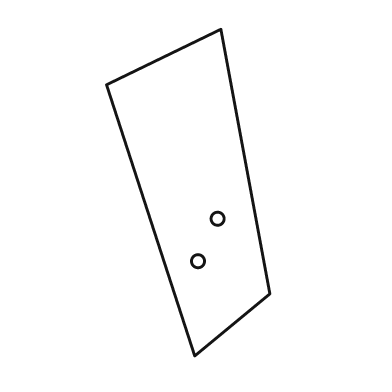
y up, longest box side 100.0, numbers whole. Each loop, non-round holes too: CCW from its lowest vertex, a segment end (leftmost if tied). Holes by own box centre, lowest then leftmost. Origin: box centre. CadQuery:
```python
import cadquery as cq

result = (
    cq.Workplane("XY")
    .moveTo(2.0, -50.0)
    .lineTo(25.0, -31.0)
    .lineTo(10.0, 50.0)
    .lineTo(-25.0, 33.0)
    .close()
    .moveTo(3.0, -21.0)
    .circle(2.0)
    .moveTo(9.0, -8.0)
    .circle(2.0)
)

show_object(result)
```